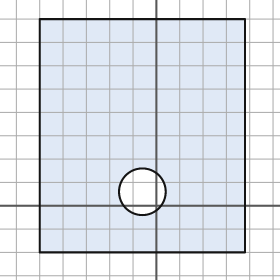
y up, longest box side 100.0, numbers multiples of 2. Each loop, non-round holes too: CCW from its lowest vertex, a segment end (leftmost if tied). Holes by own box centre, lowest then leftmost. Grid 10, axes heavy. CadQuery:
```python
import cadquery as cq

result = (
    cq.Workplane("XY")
    .moveTo(-50.0, -20.0)
    .lineTo(38.0, -20.0)
    .lineTo(38.0, 80.0)
    .lineTo(-50.0, 80.0)
    .close()
    .moveTo(-6.0, 6.0)
    .circle(10.0)
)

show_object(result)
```